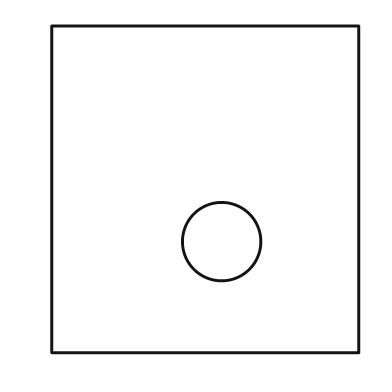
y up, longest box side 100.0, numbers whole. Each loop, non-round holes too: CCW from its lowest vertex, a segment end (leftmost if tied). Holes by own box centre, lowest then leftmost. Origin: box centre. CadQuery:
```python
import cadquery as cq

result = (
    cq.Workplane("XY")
    .moveTo(-47.0, -50.0)
    .lineTo(47.0, -50.0)
    .lineTo(47.0, 50.0)
    .lineTo(-47.0, 50.0)
    .close()
    .moveTo(5.0, -16.0)
    .circle(12.0)
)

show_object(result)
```